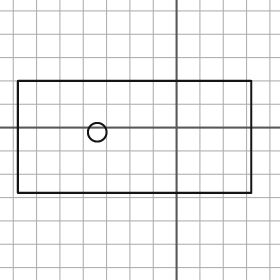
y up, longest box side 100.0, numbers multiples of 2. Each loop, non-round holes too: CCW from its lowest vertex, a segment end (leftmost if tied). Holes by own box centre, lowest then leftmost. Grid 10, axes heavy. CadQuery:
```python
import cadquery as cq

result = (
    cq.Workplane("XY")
    .moveTo(-68.0, -28.0)
    .lineTo(32.0, -28.0)
    .lineTo(32.0, 20.0)
    .lineTo(-68.0, 20.0)
    .close()
    .moveTo(-34.0, -2.0)
    .circle(4.0)
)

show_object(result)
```